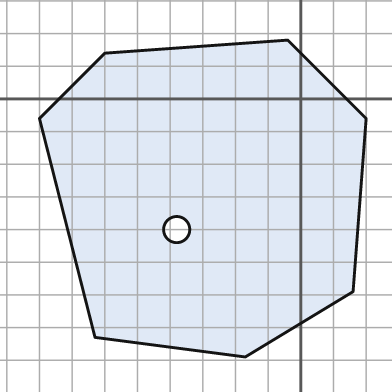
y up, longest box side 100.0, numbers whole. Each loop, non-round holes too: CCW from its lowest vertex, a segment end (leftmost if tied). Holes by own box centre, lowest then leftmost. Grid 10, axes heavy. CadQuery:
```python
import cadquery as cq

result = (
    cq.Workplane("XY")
    .moveTo(-17.0, -79.0)
    .lineTo(16.0, -59.0)
    .lineTo(20.0, -6.0)
    .lineTo(-4.0, 18.0)
    .lineTo(-60.0, 14.0)
    .lineTo(-80.0, -6.0)
    .lineTo(-63.0, -73.0)
    .close()
    .moveTo(-38.0, -40.0)
    .circle(4.0)
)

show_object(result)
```